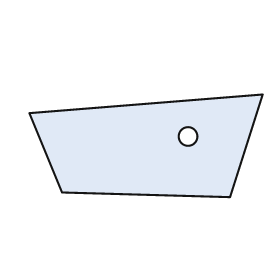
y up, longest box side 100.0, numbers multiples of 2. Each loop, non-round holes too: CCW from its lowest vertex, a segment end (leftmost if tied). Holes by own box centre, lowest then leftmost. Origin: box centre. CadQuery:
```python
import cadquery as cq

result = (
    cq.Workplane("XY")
    .moveTo(36.0, -22.0)
    .lineTo(50.0, 22.0)
    .lineTo(-50.0, 14.0)
    .lineTo(-36.0, -20.0)
    .close()
    .moveTo(18.0, 4.0)
    .circle(4.0)
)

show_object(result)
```